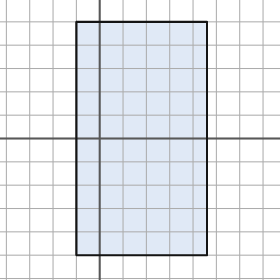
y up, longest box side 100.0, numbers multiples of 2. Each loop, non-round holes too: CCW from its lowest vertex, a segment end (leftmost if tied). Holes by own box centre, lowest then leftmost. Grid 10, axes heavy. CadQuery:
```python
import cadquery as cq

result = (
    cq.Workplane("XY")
    .moveTo(-10.0, -50.0)
    .lineTo(46.0, -50.0)
    .lineTo(46.0, 50.0)
    .lineTo(-10.0, 50.0)
    .close()
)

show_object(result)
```